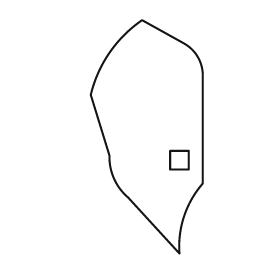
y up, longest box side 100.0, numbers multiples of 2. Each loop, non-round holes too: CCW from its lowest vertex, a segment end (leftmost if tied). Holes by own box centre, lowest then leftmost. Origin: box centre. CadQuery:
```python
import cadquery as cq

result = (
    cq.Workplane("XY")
    .moveTo(14.0, -50.0)
    .threePointArc((16.0, -34.0), (24.0, -20.0))
    .lineTo(24.0, 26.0)
    .threePointArc((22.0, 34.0), (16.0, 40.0))
    .lineTo(-2.0, 50.0)
    .threePointArc((-16.0, 36.0), (-24.0, 18.0))
    .lineTo(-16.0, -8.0)
    .threePointArc((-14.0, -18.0), (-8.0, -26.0))
    .close()
    .moveTo(10.0, -14.0)
    .lineTo(18.0, -14.0)
    .lineTo(18.0, -6.0)
    .lineTo(10.0, -6.0)
    .close()
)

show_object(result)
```